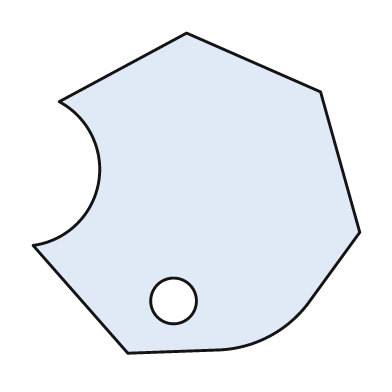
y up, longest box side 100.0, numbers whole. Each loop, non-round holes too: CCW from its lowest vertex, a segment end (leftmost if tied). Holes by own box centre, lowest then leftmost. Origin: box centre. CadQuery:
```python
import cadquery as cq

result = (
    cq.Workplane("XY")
    .moveTo(-21.0, -49.0)
    .lineTo(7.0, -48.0)
    .threePointArc((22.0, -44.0), (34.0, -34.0))
    .lineTo(50.0, -12.0)
    .lineTo(38.0, 31.0)
    .lineTo(-3.0, 49.0)
    .lineTo(-42.0, 28.0)
    .threePointArc((-30.0, 3.0), (-50.0, -16.0))
    .close()
    .moveTo(-7.0, -33.0)
    .circle(7.0)
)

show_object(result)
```